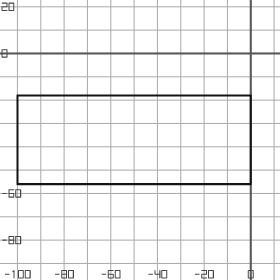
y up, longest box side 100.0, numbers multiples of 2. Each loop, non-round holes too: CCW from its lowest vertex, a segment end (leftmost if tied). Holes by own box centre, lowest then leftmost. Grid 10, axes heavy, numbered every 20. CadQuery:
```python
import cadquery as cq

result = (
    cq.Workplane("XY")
    .moveTo(-100.0, -56.0)
    .lineTo(0.0, -56.0)
    .lineTo(0.0, -18.0)
    .lineTo(-100.0, -18.0)
    .close()
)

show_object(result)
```